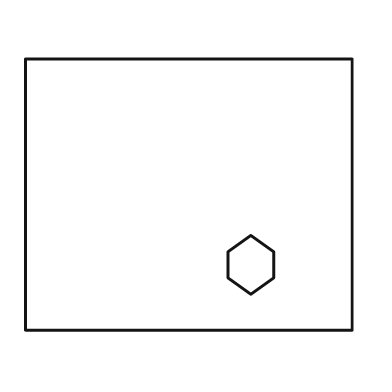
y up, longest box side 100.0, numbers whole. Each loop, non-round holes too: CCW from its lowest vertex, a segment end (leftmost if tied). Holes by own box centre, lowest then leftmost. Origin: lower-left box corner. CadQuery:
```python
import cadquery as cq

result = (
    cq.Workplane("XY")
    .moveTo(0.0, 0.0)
    .lineTo(100.0, 0.0)
    .lineTo(100.0, 83.0)
    .lineTo(0.0, 83.0)
    .close()
    .moveTo(69.0, 11.0)
    .lineTo(76.0, 16.0)
    .lineTo(76.0, 24.0)
    .lineTo(69.0, 29.0)
    .lineTo(62.0, 24.0)
    .lineTo(62.0, 16.0)
    .close()
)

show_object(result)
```